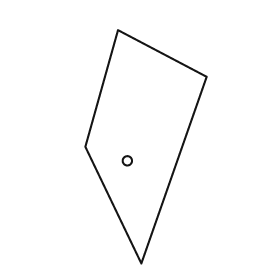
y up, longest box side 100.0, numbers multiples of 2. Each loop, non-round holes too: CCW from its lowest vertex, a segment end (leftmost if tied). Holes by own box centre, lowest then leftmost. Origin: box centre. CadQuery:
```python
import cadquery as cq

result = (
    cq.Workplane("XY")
    .moveTo(-2.0, -50.0)
    .lineTo(26.0, 30.0)
    .lineTo(-12.0, 50.0)
    .lineTo(-26.0, 0.0)
    .close()
    .moveTo(-8.0, -6.0)
    .circle(2.0)
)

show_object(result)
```